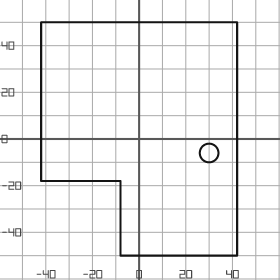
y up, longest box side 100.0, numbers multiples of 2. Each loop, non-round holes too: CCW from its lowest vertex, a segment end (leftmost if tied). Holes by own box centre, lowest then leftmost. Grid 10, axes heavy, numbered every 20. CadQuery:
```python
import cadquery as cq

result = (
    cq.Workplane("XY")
    .moveTo(-8.0, -50.0)
    .lineTo(42.0, -50.0)
    .lineTo(42.0, 50.0)
    .lineTo(-42.0, 50.0)
    .lineTo(-42.0, -18.0)
    .lineTo(-8.0, -18.0)
    .close()
    .moveTo(30.0, -6.0)
    .circle(4.0)
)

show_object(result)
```